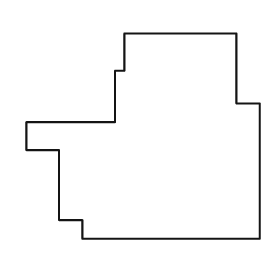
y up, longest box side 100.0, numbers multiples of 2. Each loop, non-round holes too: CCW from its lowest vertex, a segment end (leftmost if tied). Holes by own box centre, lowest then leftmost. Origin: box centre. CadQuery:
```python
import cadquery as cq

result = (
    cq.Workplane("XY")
    .moveTo(-26.0, -44.0)
    .lineTo(50.0, -44.0)
    .lineTo(50.0, 14.0)
    .lineTo(40.0, 14.0)
    .lineTo(40.0, 44.0)
    .lineTo(-8.0, 44.0)
    .lineTo(-8.0, 28.0)
    .lineTo(-12.0, 28.0)
    .lineTo(-12.0, 6.0)
    .lineTo(-50.0, 6.0)
    .lineTo(-50.0, -6.0)
    .lineTo(-36.0, -6.0)
    .lineTo(-36.0, -36.0)
    .lineTo(-26.0, -36.0)
    .close()
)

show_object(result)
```